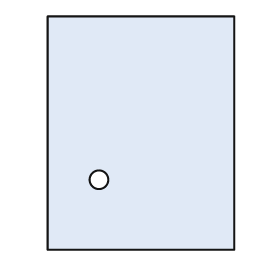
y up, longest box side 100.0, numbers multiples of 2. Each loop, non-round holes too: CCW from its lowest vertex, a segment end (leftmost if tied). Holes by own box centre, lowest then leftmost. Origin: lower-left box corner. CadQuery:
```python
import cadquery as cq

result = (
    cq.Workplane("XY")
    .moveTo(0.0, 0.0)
    .lineTo(80.0, 0.0)
    .lineTo(80.0, 100.0)
    .lineTo(0.0, 100.0)
    .close()
    .moveTo(22.0, 30.0)
    .circle(4.0)
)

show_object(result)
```